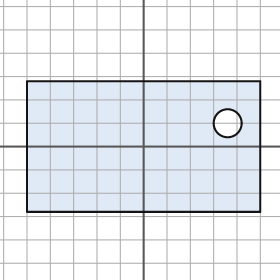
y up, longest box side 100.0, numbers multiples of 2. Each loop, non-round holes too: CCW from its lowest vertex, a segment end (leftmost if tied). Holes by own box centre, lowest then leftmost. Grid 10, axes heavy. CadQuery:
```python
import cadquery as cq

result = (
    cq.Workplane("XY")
    .moveTo(-50.0, -28.0)
    .lineTo(50.0, -28.0)
    .lineTo(50.0, 28.0)
    .lineTo(-50.0, 28.0)
    .close()
    .moveTo(36.0, 10.0)
    .circle(6.0)
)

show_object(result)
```